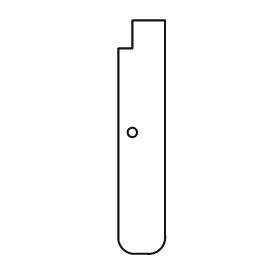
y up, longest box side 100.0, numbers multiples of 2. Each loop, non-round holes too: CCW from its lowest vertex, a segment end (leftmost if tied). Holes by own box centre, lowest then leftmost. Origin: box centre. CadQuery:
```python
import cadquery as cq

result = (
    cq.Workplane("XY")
    .moveTo(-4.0, -50.0)
    .lineTo(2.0, -50.0)
    .threePointArc((8.0, -48.0), (10.0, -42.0))
    .lineTo(10.0, 50.0)
    .lineTo(-4.0, 50.0)
    .lineTo(-4.0, 38.0)
    .lineTo(-10.0, 38.0)
    .lineTo(-10.0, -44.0)
    .threePointArc((-8.0, -48.0), (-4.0, -50.0))
    .close()
    .moveTo(-4.0, 2.0)
    .circle(2.0)
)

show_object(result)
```